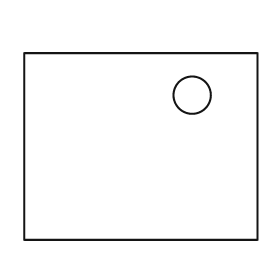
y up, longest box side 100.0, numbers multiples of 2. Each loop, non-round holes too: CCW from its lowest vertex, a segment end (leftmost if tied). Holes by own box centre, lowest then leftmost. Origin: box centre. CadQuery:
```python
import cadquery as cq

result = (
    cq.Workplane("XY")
    .moveTo(-50.0, -40.0)
    .lineTo(50.0, -40.0)
    .lineTo(50.0, 40.0)
    .lineTo(-50.0, 40.0)
    .close()
    .moveTo(22.0, 22.0)
    .circle(8.0)
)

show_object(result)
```